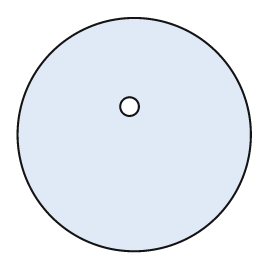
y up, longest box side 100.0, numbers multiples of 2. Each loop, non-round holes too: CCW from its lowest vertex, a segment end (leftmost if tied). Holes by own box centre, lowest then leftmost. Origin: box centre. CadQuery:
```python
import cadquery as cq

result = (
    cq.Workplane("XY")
    .moveTo(0.0, 0.0)
    .circle(50.0)
    .moveTo(-2.0, 12.0)
    .circle(4.0)
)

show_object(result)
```